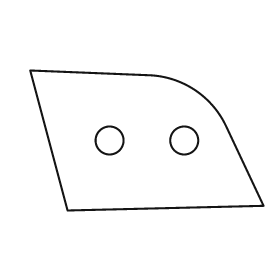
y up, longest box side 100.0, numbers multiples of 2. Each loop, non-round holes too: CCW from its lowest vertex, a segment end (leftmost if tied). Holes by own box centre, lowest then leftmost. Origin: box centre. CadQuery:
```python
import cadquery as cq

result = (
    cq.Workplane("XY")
    .moveTo(-34.0, -30.0)
    .lineTo(50.0, -28.0)
    .lineTo(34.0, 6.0)
    .threePointArc((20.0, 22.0), (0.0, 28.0))
    .lineTo(-50.0, 30.0)
    .close()
    .moveTo(-16.0, 0.0)
    .circle(6.0)
    .moveTo(16.0, 0.0)
    .circle(6.0)
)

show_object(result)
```